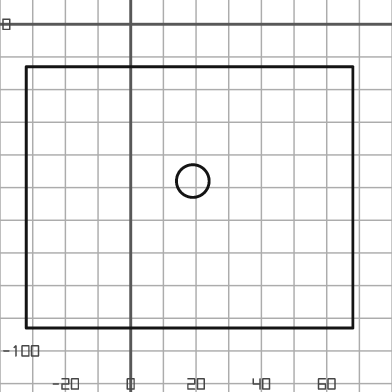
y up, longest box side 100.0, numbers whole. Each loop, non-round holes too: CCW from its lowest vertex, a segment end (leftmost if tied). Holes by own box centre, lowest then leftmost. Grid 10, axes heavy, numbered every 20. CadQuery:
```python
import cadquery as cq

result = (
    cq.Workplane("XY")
    .moveTo(-32.0, -93.0)
    .lineTo(68.0, -93.0)
    .lineTo(68.0, -13.0)
    .lineTo(-32.0, -13.0)
    .close()
    .moveTo(19.0, -48.0)
    .circle(5.0)
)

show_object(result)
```